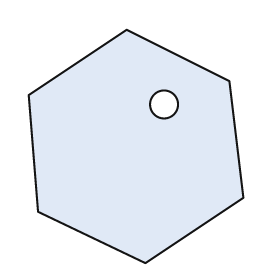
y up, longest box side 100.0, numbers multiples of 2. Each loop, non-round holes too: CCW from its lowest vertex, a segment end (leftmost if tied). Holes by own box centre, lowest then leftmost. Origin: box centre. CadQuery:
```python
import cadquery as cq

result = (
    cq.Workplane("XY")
    .moveTo(4.0, -50.0)
    .lineTo(46.0, -22.0)
    .lineTo(40.0, 28.0)
    .lineTo(-4.0, 50.0)
    .lineTo(-46.0, 22.0)
    .lineTo(-42.0, -28.0)
    .close()
    .moveTo(12.0, 18.0)
    .circle(6.0)
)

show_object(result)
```